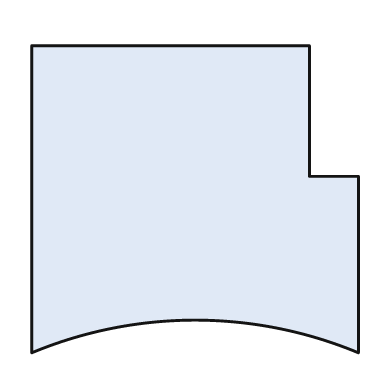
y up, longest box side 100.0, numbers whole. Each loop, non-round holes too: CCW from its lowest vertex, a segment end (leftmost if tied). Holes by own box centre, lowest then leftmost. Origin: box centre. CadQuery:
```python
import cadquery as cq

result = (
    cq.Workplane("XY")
    .moveTo(-50.0, -47.0)
    .threePointArc((0.0, -37.0), (50.0, -47.0))
    .lineTo(50.0, 7.0)
    .lineTo(35.0, 7.0)
    .lineTo(35.0, 47.0)
    .lineTo(-50.0, 47.0)
    .close()
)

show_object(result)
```